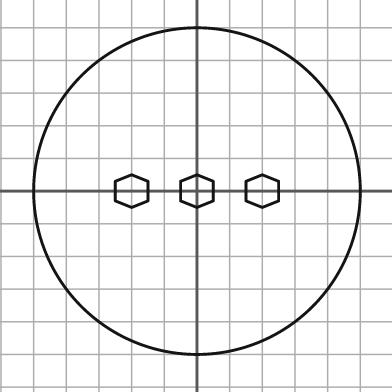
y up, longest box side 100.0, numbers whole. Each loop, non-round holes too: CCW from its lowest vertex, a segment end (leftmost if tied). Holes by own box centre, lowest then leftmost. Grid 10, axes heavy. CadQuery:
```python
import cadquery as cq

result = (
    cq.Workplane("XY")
    .moveTo(0.0, 0.0)
    .circle(50.0)
    .moveTo(-20.0, -5.0)
    .lineTo(-15.0, -3.0)
    .lineTo(-15.0, 3.0)
    .lineTo(-20.0, 5.0)
    .lineTo(-25.0, 3.0)
    .lineTo(-25.0, -3.0)
    .close()
    .moveTo(0.0, -5.0)
    .lineTo(5.0, -3.0)
    .lineTo(5.0, 3.0)
    .lineTo(0.0, 5.0)
    .lineTo(-5.0, 3.0)
    .lineTo(-5.0, -3.0)
    .close()
    .moveTo(20.0, -5.0)
    .lineTo(25.0, -3.0)
    .lineTo(25.0, 3.0)
    .lineTo(20.0, 5.0)
    .lineTo(15.0, 3.0)
    .lineTo(15.0, -3.0)
    .close()
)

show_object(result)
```